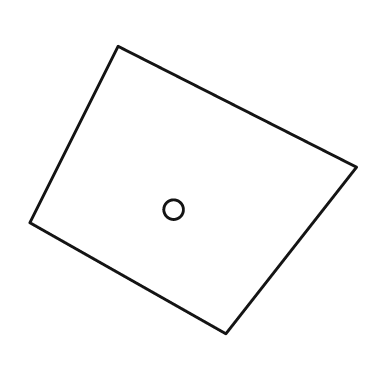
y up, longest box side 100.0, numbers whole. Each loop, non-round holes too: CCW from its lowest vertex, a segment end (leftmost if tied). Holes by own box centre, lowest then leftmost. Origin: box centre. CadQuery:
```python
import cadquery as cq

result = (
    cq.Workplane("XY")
    .moveTo(10.0, -44.0)
    .lineTo(50.0, 7.0)
    .lineTo(-23.0, 44.0)
    .lineTo(-50.0, -10.0)
    .close()
    .moveTo(-6.0, -6.0)
    .circle(3.0)
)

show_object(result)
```